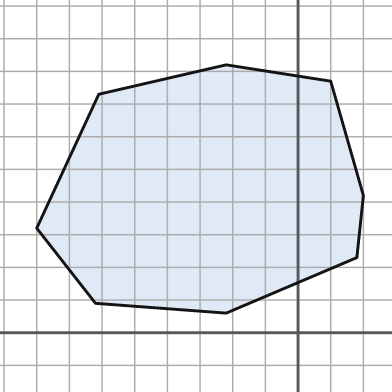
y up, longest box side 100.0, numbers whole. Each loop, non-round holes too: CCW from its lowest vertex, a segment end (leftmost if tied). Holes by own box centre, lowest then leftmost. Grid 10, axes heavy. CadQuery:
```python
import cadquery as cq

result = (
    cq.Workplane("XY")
    .moveTo(-22.0, 6.0)
    .lineTo(18.0, 23.0)
    .lineTo(20.0, 42.0)
    .lineTo(10.0, 77.0)
    .lineTo(-22.0, 82.0)
    .lineTo(-61.0, 73.0)
    .lineTo(-80.0, 32.0)
    .lineTo(-62.0, 9.0)
    .close()
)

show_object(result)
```